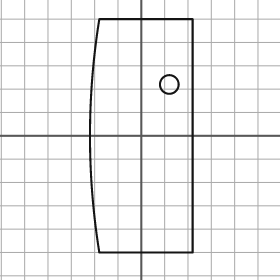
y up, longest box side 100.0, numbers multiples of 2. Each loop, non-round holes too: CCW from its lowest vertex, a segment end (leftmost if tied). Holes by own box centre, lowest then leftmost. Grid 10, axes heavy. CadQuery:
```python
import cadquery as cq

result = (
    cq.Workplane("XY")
    .moveTo(-18.0, -50.0)
    .lineTo(22.0, -50.0)
    .lineTo(22.0, 50.0)
    .lineTo(-18.0, 50.0)
    .threePointArc((-22.0, 0.0), (-18.0, -50.0))
    .close()
    .moveTo(12.0, 22.0)
    .circle(4.0)
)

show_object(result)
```